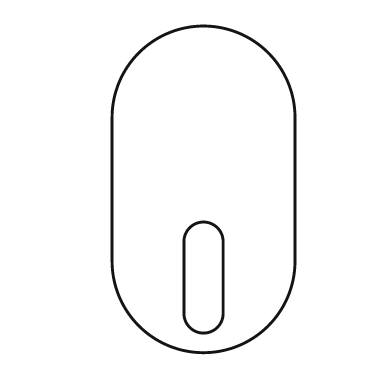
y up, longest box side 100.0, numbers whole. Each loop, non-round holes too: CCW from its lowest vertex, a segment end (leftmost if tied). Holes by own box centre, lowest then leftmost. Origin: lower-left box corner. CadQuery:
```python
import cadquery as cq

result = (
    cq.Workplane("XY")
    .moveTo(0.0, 28.0)
    .threePointArc((28.0, 0.0), (56.0, 28.0))
    .lineTo(56.0, 72.0)
    .threePointArc((28.0, 100.0), (0.0, 72.0))
    .close()
    .moveTo(22.0, 12.0)
    .threePointArc((28.0, 6.0), (34.0, 12.0))
    .lineTo(34.0, 34.0)
    .threePointArc((28.0, 40.0), (22.0, 34.0))
    .close()
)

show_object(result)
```